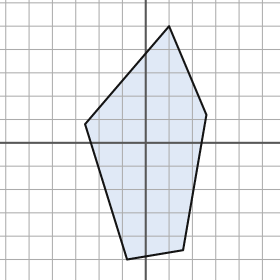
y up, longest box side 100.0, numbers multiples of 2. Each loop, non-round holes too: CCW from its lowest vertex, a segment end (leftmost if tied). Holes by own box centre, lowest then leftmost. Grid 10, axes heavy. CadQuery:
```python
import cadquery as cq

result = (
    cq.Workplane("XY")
    .moveTo(-8.0, -50.0)
    .lineTo(16.0, -46.0)
    .lineTo(26.0, 12.0)
    .lineTo(10.0, 50.0)
    .lineTo(-26.0, 8.0)
    .close()
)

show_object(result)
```